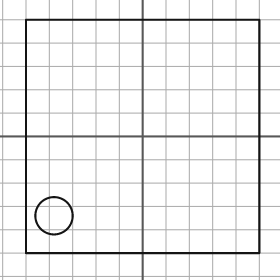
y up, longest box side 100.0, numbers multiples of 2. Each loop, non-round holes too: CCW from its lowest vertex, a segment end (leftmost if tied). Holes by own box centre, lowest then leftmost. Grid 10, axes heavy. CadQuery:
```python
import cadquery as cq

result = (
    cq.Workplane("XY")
    .moveTo(-50.0, -50.0)
    .lineTo(50.0, -50.0)
    .lineTo(50.0, 50.0)
    .lineTo(-50.0, 50.0)
    .close()
    .moveTo(-38.0, -34.0)
    .circle(8.0)
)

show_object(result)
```